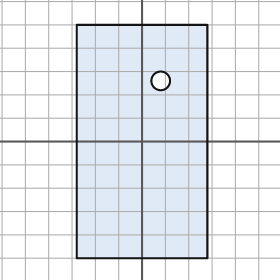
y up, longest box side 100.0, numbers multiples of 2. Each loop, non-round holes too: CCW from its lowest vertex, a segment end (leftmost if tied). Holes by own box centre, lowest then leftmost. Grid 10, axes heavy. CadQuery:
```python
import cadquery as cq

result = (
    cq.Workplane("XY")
    .moveTo(-28.0, -50.0)
    .lineTo(28.0, -50.0)
    .lineTo(28.0, 50.0)
    .lineTo(-28.0, 50.0)
    .close()
    .moveTo(8.0, 26.0)
    .circle(4.0)
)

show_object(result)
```